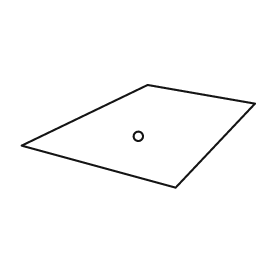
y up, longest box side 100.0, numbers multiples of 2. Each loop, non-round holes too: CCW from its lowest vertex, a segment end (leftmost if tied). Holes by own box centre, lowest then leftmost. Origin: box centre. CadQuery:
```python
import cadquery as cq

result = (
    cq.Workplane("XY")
    .moveTo(16.0, -22.0)
    .lineTo(50.0, 14.0)
    .lineTo(4.0, 22.0)
    .lineTo(-50.0, -4.0)
    .close()
    .moveTo(0.0, 0.0)
    .circle(2.0)
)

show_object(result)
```